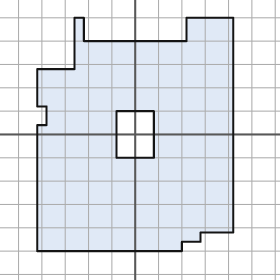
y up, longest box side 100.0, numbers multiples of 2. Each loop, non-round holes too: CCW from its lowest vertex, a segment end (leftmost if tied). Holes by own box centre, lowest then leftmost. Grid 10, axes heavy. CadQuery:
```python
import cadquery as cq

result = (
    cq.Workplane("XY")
    .moveTo(-42.0, -50.0)
    .lineTo(20.0, -50.0)
    .lineTo(20.0, -46.0)
    .lineTo(28.0, -46.0)
    .lineTo(28.0, -42.0)
    .lineTo(42.0, -42.0)
    .lineTo(42.0, 50.0)
    .lineTo(22.0, 50.0)
    .lineTo(22.0, 40.0)
    .lineTo(-22.0, 40.0)
    .lineTo(-22.0, 50.0)
    .lineTo(-26.0, 50.0)
    .lineTo(-26.0, 28.0)
    .lineTo(-42.0, 28.0)
    .lineTo(-42.0, 12.0)
    .lineTo(-38.0, 12.0)
    .lineTo(-38.0, 4.0)
    .lineTo(-42.0, 4.0)
    .close()
    .moveTo(-8.0, -10.0)
    .lineTo(8.0, -10.0)
    .lineTo(8.0, 10.0)
    .lineTo(-8.0, 10.0)
    .close()
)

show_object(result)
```